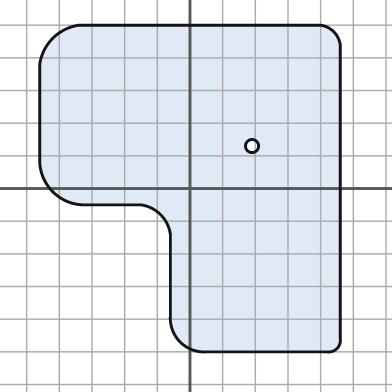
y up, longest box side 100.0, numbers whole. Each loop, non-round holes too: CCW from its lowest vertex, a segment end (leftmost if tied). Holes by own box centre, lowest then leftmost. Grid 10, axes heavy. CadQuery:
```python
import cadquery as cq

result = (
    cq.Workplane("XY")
    .moveTo(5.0, -50.0)
    .lineTo(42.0, -50.0)
    .threePointArc((45.0, -49.0), (46.0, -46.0))
    .lineTo(46.0, 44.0)
    .threePointArc((44.0, 48.0), (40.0, 50.0))
    .lineTo(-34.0, 50.0)
    .threePointArc((-42.0, 46.0), (-46.0, 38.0))
    .lineTo(-46.0, 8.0)
    .threePointArc((-42.0, -1.0), (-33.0, -5.0))
    .lineTo(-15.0, -5.0)
    .threePointArc((-9.0, -8.0), (-6.0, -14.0))
    .lineTo(-6.0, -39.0)
    .threePointArc((-3.0, -47.0), (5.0, -50.0))
    .close()
    .moveTo(19.0, 13.0)
    .circle(2.0)
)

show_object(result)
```